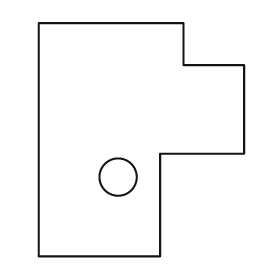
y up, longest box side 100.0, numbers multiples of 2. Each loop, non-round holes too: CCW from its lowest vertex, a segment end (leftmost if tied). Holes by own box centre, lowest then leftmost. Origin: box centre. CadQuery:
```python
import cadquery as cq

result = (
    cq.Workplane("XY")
    .moveTo(-44.0, -50.0)
    .lineTo(8.0, -50.0)
    .lineTo(8.0, -6.0)
    .lineTo(44.0, -6.0)
    .lineTo(44.0, 32.0)
    .lineTo(18.0, 32.0)
    .lineTo(18.0, 50.0)
    .lineTo(-44.0, 50.0)
    .close()
    .moveTo(-10.0, -16.0)
    .circle(8.0)
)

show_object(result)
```